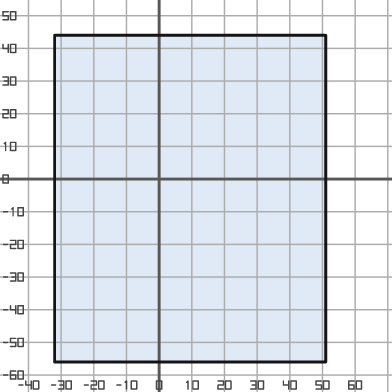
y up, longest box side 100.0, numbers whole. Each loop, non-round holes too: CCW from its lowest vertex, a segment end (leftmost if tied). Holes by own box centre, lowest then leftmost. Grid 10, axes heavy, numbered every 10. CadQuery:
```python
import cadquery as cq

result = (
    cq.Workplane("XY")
    .moveTo(-32.0, -56.0)
    .lineTo(51.0, -56.0)
    .lineTo(51.0, 44.0)
    .lineTo(-32.0, 44.0)
    .close()
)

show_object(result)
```